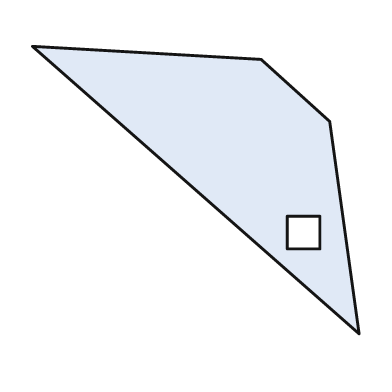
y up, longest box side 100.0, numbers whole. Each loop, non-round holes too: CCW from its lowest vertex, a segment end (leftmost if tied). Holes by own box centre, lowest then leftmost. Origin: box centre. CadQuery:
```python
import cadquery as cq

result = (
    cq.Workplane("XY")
    .moveTo(50.0, -44.0)
    .lineTo(41.0, 21.0)
    .lineTo(20.0, 40.0)
    .lineTo(-50.0, 44.0)
    .close()
    .moveTo(28.0, -18.0)
    .lineTo(38.0, -18.0)
    .lineTo(38.0, -8.0)
    .lineTo(28.0, -8.0)
    .close()
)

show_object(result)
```